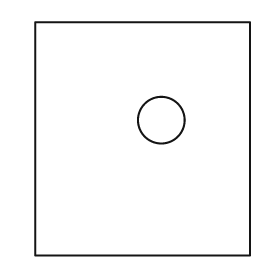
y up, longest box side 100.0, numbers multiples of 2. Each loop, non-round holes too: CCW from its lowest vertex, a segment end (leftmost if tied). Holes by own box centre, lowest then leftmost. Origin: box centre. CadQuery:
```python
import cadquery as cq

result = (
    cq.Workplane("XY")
    .moveTo(-46.0, -50.0)
    .lineTo(46.0, -50.0)
    .lineTo(46.0, 50.0)
    .lineTo(-46.0, 50.0)
    .close()
    .moveTo(8.0, 8.0)
    .circle(10.0)
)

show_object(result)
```